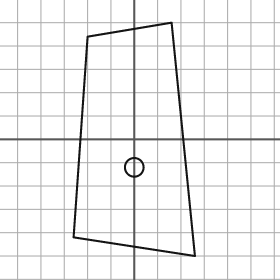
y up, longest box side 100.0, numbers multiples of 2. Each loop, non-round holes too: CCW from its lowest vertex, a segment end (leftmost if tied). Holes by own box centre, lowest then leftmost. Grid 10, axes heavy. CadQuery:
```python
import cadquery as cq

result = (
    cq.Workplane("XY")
    .moveTo(26.0, -50.0)
    .lineTo(16.0, 50.0)
    .lineTo(-20.0, 44.0)
    .lineTo(-26.0, -42.0)
    .close()
    .moveTo(0.0, -12.0)
    .circle(4.0)
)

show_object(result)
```